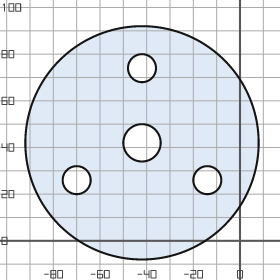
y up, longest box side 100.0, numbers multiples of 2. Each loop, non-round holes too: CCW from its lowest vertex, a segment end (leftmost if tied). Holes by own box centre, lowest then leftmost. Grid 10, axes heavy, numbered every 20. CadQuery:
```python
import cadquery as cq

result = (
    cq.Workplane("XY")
    .moveTo(-42.0, 42.0)
    .circle(50.0)
    .moveTo(-70.0, 26.0)
    .circle(6.0)
    .moveTo(-14.0, 26.0)
    .circle(6.0)
    .moveTo(-42.0, 42.0)
    .circle(8.0)
    .moveTo(-42.0, 74.0)
    .circle(6.0)
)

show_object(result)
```